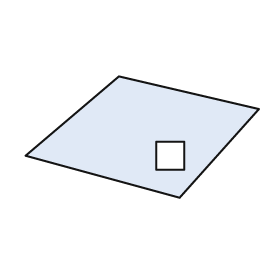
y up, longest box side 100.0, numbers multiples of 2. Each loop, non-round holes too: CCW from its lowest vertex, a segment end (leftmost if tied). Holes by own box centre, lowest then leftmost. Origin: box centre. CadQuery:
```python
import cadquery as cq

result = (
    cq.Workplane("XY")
    .moveTo(16.0, -26.0)
    .lineTo(50.0, 12.0)
    .lineTo(-10.0, 26.0)
    .lineTo(-50.0, -8.0)
    .close()
    .moveTo(6.0, -14.0)
    .lineTo(18.0, -14.0)
    .lineTo(18.0, -2.0)
    .lineTo(6.0, -2.0)
    .close()
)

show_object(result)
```